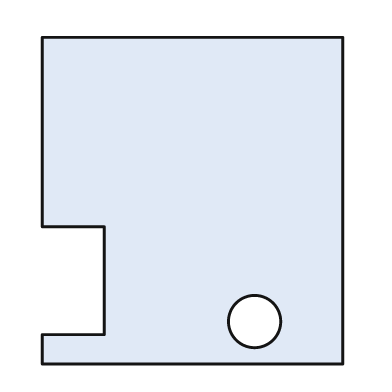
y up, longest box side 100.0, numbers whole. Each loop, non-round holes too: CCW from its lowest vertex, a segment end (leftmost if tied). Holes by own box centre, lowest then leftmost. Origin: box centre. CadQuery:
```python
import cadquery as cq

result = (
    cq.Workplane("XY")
    .moveTo(-46.0, -50.0)
    .lineTo(46.0, -50.0)
    .lineTo(46.0, 50.0)
    .lineTo(-46.0, 50.0)
    .lineTo(-46.0, -8.0)
    .lineTo(-27.0, -8.0)
    .lineTo(-27.0, -41.0)
    .lineTo(-46.0, -41.0)
    .close()
    .moveTo(19.0, -37.0)
    .circle(8.0)
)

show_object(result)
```